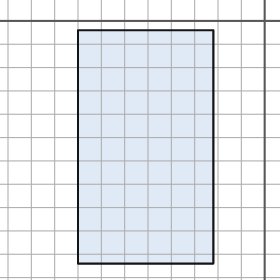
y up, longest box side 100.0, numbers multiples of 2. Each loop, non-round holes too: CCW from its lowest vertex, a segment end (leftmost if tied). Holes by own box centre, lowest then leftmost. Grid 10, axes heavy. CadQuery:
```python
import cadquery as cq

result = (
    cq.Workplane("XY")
    .moveTo(-80.0, -104.0)
    .lineTo(-22.0, -104.0)
    .lineTo(-22.0, -4.0)
    .lineTo(-80.0, -4.0)
    .close()
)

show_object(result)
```